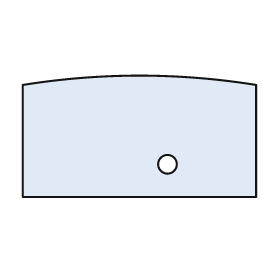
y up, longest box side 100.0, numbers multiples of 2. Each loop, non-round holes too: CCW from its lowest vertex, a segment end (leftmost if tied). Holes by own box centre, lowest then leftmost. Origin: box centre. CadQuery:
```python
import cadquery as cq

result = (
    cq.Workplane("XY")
    .moveTo(-50.0, -26.0)
    .lineTo(50.0, -26.0)
    .lineTo(50.0, 22.0)
    .threePointArc((0.0, 26.0), (-50.0, 22.0))
    .close()
    .moveTo(12.0, -12.0)
    .circle(4.0)
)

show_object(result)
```